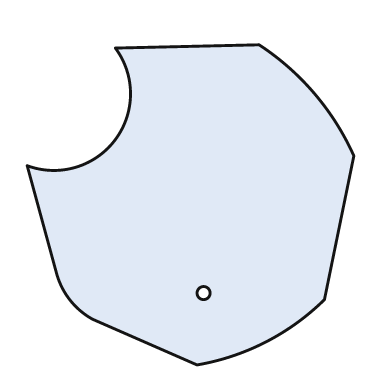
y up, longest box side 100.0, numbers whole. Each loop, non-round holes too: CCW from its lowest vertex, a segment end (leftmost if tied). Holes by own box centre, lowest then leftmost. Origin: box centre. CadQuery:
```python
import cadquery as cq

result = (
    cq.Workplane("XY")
    .moveTo(2.0, -49.0)
    .threePointArc((23.0, -42.0), (41.0, -29.0))
    .lineTo(50.0, 15.0)
    .threePointArc((38.0, 34.0), (21.0, 49.0))
    .lineTo(-23.0, 48.0)
    .threePointArc((-23.0, 20.0), (-50.0, 12.0))
    .lineTo(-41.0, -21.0)
    .threePointArc((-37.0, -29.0), (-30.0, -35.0))
    .close()
    .moveTo(4.0, -27.0)
    .circle(2.0)
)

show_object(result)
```